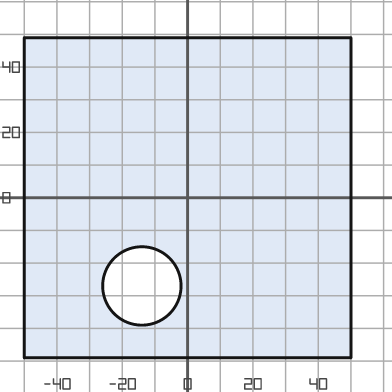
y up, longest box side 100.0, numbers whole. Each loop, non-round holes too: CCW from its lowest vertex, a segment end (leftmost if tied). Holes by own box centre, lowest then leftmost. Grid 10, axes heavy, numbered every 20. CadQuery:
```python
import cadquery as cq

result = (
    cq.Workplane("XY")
    .moveTo(-50.0, -49.0)
    .lineTo(50.0, -49.0)
    .lineTo(50.0, 49.0)
    .lineTo(-50.0, 49.0)
    .close()
    .moveTo(-14.0, -27.0)
    .circle(12.0)
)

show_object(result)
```